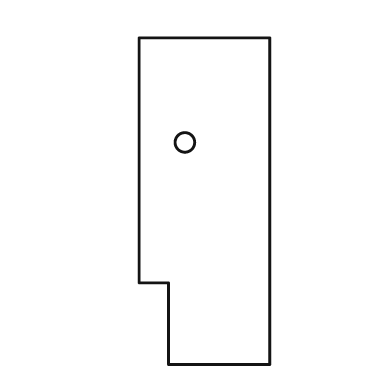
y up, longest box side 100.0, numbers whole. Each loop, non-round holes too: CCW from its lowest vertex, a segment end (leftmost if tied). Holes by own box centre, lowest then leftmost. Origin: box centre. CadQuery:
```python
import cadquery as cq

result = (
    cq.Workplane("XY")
    .moveTo(-11.0, -50.0)
    .lineTo(20.0, -50.0)
    .lineTo(20.0, 50.0)
    .lineTo(-20.0, 50.0)
    .lineTo(-20.0, -25.0)
    .lineTo(-11.0, -25.0)
    .close()
    .moveTo(-6.0, 18.0)
    .circle(3.0)
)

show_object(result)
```